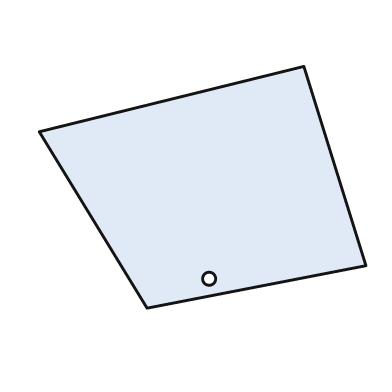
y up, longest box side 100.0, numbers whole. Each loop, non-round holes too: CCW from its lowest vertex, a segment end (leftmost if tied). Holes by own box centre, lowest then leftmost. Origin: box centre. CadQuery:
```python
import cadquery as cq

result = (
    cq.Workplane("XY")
    .moveTo(-17.0, -37.0)
    .lineTo(50.0, -24.0)
    .lineTo(31.0, 37.0)
    .lineTo(-50.0, 17.0)
    .close()
    .moveTo(2.0, -28.0)
    .circle(2.0)
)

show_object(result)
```